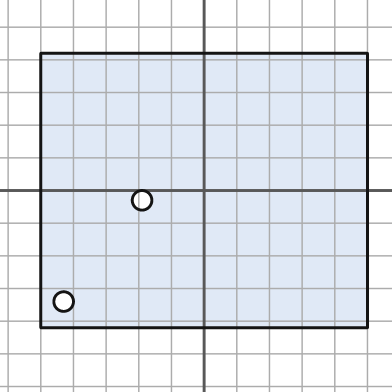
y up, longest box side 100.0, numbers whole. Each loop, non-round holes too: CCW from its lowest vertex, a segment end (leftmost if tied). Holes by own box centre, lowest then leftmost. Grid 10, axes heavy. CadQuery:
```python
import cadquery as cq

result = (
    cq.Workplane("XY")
    .moveTo(-50.0, -42.0)
    .lineTo(50.0, -42.0)
    .lineTo(50.0, 42.0)
    .lineTo(-50.0, 42.0)
    .close()
    .moveTo(-43.0, -34.0)
    .circle(3.0)
    .moveTo(-19.0, -3.0)
    .circle(3.0)
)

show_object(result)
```